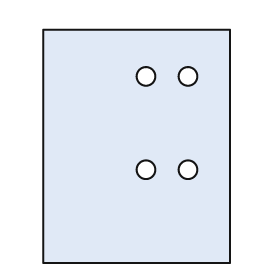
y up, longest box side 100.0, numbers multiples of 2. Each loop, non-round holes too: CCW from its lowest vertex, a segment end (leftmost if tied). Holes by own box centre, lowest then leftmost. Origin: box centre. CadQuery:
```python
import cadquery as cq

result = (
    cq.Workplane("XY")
    .moveTo(-40.0, -50.0)
    .lineTo(40.0, -50.0)
    .lineTo(40.0, 50.0)
    .lineTo(-40.0, 50.0)
    .close()
    .moveTo(4.0, -10.0)
    .circle(4.0)
    .moveTo(22.0, -10.0)
    .circle(4.0)
    .moveTo(4.0, 30.0)
    .circle(4.0)
    .moveTo(22.0, 30.0)
    .circle(4.0)
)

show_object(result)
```